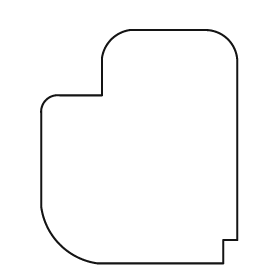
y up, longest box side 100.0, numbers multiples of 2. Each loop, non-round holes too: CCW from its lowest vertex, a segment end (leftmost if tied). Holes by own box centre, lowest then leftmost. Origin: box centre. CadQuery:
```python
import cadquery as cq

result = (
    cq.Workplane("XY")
    .moveTo(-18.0, -50.0)
    .lineTo(36.0, -50.0)
    .lineTo(36.0, -40.0)
    .lineTo(42.0, -40.0)
    .lineTo(42.0, 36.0)
    .threePointArc((38.0, 46.0), (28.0, 50.0))
    .lineTo(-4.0, 50.0)
    .threePointArc((-12.0, 46.0), (-16.0, 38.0))
    .lineTo(-16.0, 22.0)
    .lineTo(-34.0, 22.0)
    .threePointArc((-40.0, 20.0), (-42.0, 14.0))
    .lineTo(-42.0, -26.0)
    .threePointArc((-34.0, -42.0), (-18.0, -50.0))
    .close()
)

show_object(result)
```